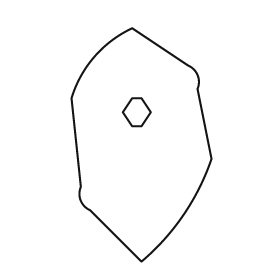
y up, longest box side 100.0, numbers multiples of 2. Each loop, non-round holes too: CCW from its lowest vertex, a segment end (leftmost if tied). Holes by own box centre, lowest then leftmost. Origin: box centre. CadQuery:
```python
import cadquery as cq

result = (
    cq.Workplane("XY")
    .moveTo(0.0, -50.0)
    .threePointArc((18.0, -30.0), (30.0, -6.0))
    .lineTo(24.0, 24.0)
    .threePointArc((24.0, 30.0), (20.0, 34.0))
    .lineTo(-4.0, 50.0)
    .threePointArc((-20.0, 38.0), (-30.0, 20.0))
    .lineTo(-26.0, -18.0)
    .threePointArc((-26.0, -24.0), (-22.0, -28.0))
    .close()
    .moveTo(-4.0, 8.0)
    .lineTo(0.0, 8.0)
    .lineTo(4.0, 14.0)
    .lineTo(0.0, 20.0)
    .lineTo(-4.0, 20.0)
    .lineTo(-8.0, 14.0)
    .close()
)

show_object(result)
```